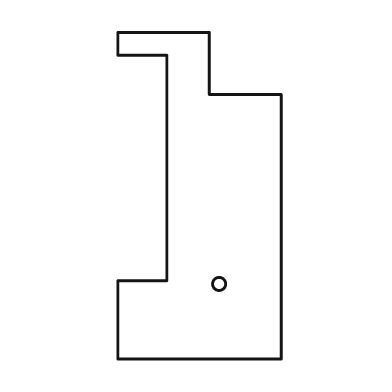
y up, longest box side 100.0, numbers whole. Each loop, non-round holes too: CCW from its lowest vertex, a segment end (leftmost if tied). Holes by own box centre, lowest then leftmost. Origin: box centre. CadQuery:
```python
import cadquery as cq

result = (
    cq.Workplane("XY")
    .moveTo(-25.0, -50.0)
    .lineTo(25.0, -50.0)
    .lineTo(25.0, 31.0)
    .lineTo(3.0, 31.0)
    .lineTo(3.0, 50.0)
    .lineTo(-25.0, 50.0)
    .lineTo(-25.0, 43.0)
    .lineTo(-10.0, 43.0)
    .lineTo(-10.0, -26.0)
    .lineTo(-25.0, -26.0)
    .close()
    .moveTo(6.0, -27.0)
    .circle(2.0)
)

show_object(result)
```